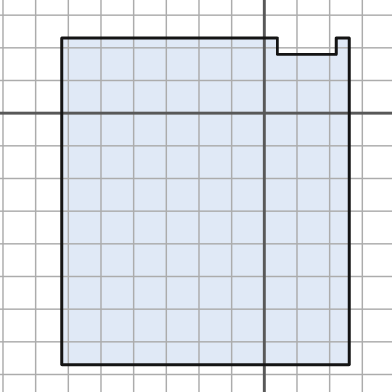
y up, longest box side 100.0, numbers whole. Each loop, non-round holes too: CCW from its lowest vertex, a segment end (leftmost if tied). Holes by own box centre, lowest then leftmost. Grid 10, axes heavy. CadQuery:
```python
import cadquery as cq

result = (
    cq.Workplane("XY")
    .moveTo(-62.0, -77.0)
    .lineTo(26.0, -77.0)
    .lineTo(26.0, 23.0)
    .lineTo(22.0, 23.0)
    .lineTo(22.0, 18.0)
    .lineTo(4.0, 18.0)
    .lineTo(4.0, 23.0)
    .lineTo(-62.0, 23.0)
    .close()
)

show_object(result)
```